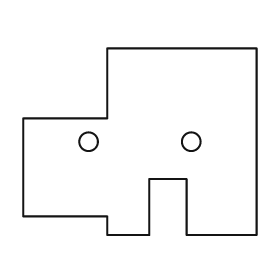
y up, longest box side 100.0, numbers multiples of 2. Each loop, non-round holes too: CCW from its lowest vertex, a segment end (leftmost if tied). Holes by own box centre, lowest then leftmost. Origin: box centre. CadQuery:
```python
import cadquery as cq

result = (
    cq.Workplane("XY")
    .moveTo(-14.0, -40.0)
    .lineTo(4.0, -40.0)
    .lineTo(4.0, -16.0)
    .lineTo(20.0, -16.0)
    .lineTo(20.0, -40.0)
    .lineTo(50.0, -40.0)
    .lineTo(50.0, 40.0)
    .lineTo(-14.0, 40.0)
    .lineTo(-14.0, 10.0)
    .lineTo(-50.0, 10.0)
    .lineTo(-50.0, -32.0)
    .lineTo(-14.0, -32.0)
    .close()
    .moveTo(-22.0, 0.0)
    .circle(4.0)
    .moveTo(22.0, 0.0)
    .circle(4.0)
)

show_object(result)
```